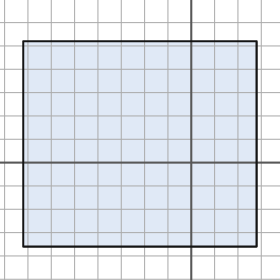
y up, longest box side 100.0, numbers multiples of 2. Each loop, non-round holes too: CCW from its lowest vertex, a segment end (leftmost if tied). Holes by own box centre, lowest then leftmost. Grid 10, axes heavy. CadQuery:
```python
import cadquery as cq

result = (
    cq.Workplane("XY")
    .moveTo(-72.0, -36.0)
    .lineTo(28.0, -36.0)
    .lineTo(28.0, 52.0)
    .lineTo(-72.0, 52.0)
    .close()
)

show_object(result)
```